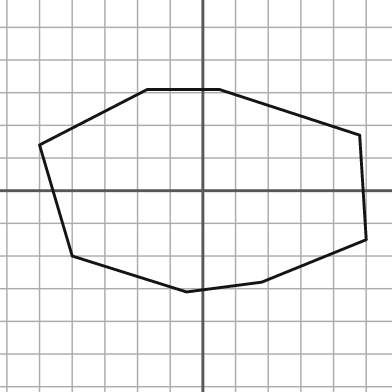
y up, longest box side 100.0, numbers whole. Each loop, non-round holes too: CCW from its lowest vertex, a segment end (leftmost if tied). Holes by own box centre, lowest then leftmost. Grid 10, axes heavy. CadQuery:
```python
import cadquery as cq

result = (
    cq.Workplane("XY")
    .moveTo(-5.0, -31.0)
    .lineTo(18.0, -28.0)
    .lineTo(50.0, -15.0)
    .lineTo(48.0, 17.0)
    .lineTo(5.0, 31.0)
    .lineTo(-17.0, 31.0)
    .lineTo(-50.0, 14.0)
    .lineTo(-40.0, -20.0)
    .close()
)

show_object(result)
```